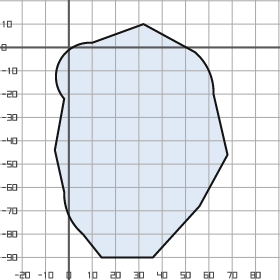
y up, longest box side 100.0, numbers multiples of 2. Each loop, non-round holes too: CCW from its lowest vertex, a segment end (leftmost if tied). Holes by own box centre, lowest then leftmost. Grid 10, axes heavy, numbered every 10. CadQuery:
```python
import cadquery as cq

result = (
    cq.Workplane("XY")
    .moveTo(14.0, -90.0)
    .lineTo(36.0, -90.0)
    .lineTo(56.0, -68.0)
    .lineTo(68.0, -46.0)
    .lineTo(62.0, -20.0)
    .threePointArc((60.0, -10.0), (54.0, -2.0))
    .lineTo(32.0, 10.0)
    .lineTo(10.0, 2.0)
    .threePointArc((-4.0, -6.0), (-2.0, -22.0))
    .lineTo(-6.0, -44.0)
    .lineTo(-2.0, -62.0)
    .threePointArc((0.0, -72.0), (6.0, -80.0))
    .close()
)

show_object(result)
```